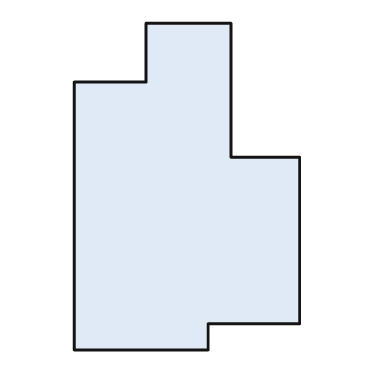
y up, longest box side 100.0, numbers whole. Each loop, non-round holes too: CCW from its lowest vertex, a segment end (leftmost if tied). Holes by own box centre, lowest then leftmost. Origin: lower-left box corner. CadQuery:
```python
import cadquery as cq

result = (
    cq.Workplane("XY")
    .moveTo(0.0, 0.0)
    .lineTo(41.0, 0.0)
    .lineTo(41.0, 8.0)
    .lineTo(69.0, 8.0)
    .lineTo(69.0, 59.0)
    .lineTo(48.0, 59.0)
    .lineTo(48.0, 100.0)
    .lineTo(22.0, 100.0)
    .lineTo(22.0, 82.0)
    .lineTo(0.0, 82.0)
    .close()
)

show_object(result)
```